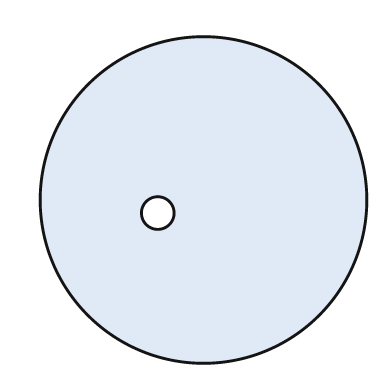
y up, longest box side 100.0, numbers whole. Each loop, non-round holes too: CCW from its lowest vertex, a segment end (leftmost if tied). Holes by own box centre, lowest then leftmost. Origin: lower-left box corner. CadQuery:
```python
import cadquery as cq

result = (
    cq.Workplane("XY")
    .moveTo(50.0, 50.0)
    .circle(50.0)
    .moveTo(36.0, 46.0)
    .circle(5.0)
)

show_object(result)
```